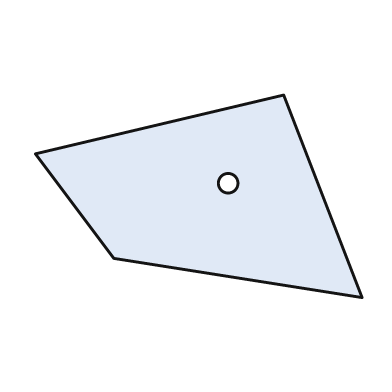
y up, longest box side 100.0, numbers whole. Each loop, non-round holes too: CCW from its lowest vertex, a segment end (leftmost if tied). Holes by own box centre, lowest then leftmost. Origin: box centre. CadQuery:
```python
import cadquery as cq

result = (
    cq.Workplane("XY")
    .moveTo(50.0, -31.0)
    .lineTo(26.0, 31.0)
    .lineTo(-50.0, 13.0)
    .lineTo(-26.0, -19.0)
    .close()
    .moveTo(9.0, 4.0)
    .circle(3.0)
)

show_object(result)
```